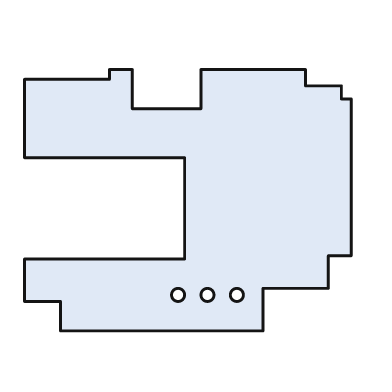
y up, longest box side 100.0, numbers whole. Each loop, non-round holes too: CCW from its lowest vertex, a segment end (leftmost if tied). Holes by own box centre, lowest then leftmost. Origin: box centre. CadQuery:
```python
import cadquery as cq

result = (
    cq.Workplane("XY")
    .moveTo(-39.0, -40.0)
    .lineTo(23.0, -40.0)
    .lineTo(23.0, -27.0)
    .lineTo(43.0, -27.0)
    .lineTo(43.0, -17.0)
    .lineTo(50.0, -17.0)
    .lineTo(50.0, 31.0)
    .lineTo(47.0, 31.0)
    .lineTo(47.0, 35.0)
    .lineTo(36.0, 35.0)
    .lineTo(36.0, 40.0)
    .lineTo(4.0, 40.0)
    .lineTo(4.0, 28.0)
    .lineTo(-17.0, 28.0)
    .lineTo(-17.0, 40.0)
    .lineTo(-24.0, 40.0)
    .lineTo(-24.0, 37.0)
    .lineTo(-50.0, 37.0)
    .lineTo(-50.0, 13.0)
    .lineTo(-1.0, 13.0)
    .lineTo(-1.0, -18.0)
    .lineTo(-50.0, -18.0)
    .lineTo(-50.0, -31.0)
    .lineTo(-39.0, -31.0)
    .close()
    .moveTo(-3.0, -29.0)
    .circle(2.0)
    .moveTo(6.0, -29.0)
    .circle(2.0)
    .moveTo(15.0, -29.0)
    .circle(2.0)
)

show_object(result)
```